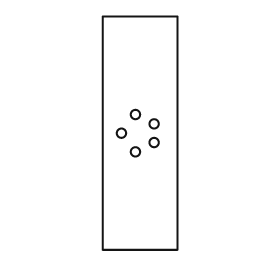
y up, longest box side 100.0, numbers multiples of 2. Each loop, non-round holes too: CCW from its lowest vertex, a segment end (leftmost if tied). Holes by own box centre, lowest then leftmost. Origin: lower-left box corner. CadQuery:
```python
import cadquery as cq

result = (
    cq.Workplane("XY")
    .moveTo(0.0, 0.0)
    .lineTo(32.0, 0.0)
    .lineTo(32.0, 100.0)
    .lineTo(0.0, 100.0)
    .close()
    .moveTo(14.0, 42.0)
    .circle(2.0)
    .moveTo(22.0, 46.0)
    .circle(2.0)
    .moveTo(8.0, 50.0)
    .circle(2.0)
    .moveTo(22.0, 54.0)
    .circle(2.0)
    .moveTo(14.0, 58.0)
    .circle(2.0)
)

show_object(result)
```